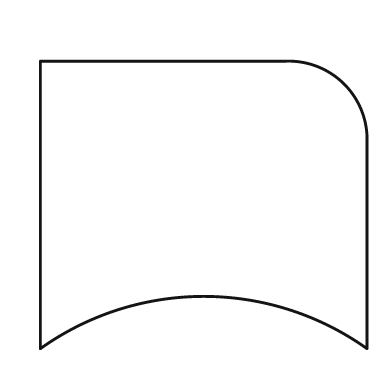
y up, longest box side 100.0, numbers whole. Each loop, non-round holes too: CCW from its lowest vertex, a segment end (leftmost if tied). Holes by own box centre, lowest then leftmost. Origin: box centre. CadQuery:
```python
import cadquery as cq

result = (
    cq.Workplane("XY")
    .moveTo(-50.0, -44.0)
    .threePointArc((0.0, -28.0), (50.0, -44.0))
    .lineTo(50.0, 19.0)
    .threePointArc((43.0, 37.0), (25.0, 44.0))
    .lineTo(-50.0, 44.0)
    .close()
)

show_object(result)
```